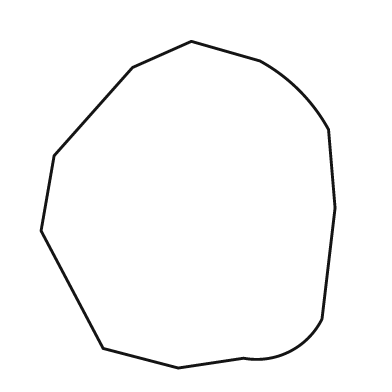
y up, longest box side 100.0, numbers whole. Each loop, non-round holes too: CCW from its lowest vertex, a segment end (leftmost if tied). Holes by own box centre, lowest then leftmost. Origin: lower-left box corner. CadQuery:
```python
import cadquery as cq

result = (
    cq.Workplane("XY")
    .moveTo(42.0, 0.0)
    .lineTo(62.0, 3.0)
    .threePointArc((76.0, 5.0), (86.0, 15.0))
    .lineTo(90.0, 49.0)
    .lineTo(88.0, 73.0)
    .threePointArc((79.0, 85.0), (67.0, 94.0))
    .lineTo(46.0, 100.0)
    .lineTo(28.0, 92.0)
    .lineTo(4.0, 65.0)
    .lineTo(0.0, 42.0)
    .lineTo(19.0, 6.0)
    .close()
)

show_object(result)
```